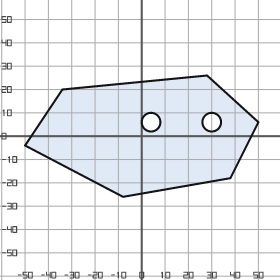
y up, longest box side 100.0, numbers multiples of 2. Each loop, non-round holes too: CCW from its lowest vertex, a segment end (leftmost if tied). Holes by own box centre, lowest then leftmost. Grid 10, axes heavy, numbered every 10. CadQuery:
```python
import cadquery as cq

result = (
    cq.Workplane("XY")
    .moveTo(-8.0, -26.0)
    .lineTo(38.0, -18.0)
    .lineTo(50.0, 6.0)
    .lineTo(28.0, 26.0)
    .lineTo(-34.0, 20.0)
    .lineTo(-50.0, -4.0)
    .close()
    .moveTo(4.0, 6.0)
    .circle(4.0)
    .moveTo(30.0, 6.0)
    .circle(4.0)
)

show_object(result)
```